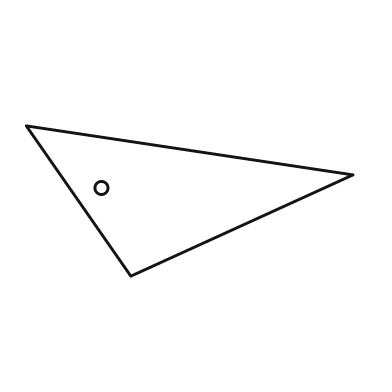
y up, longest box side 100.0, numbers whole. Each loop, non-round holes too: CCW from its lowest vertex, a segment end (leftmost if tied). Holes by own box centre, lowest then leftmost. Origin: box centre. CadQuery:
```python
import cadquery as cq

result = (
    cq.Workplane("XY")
    .moveTo(-18.0, -23.0)
    .lineTo(50.0, 8.0)
    .lineTo(-50.0, 23.0)
    .close()
    .moveTo(-27.0, 4.0)
    .circle(2.0)
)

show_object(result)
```